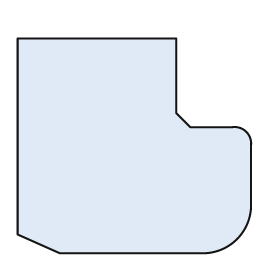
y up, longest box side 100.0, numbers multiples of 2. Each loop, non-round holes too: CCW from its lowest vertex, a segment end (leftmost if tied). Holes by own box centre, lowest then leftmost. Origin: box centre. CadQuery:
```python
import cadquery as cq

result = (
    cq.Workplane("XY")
    .moveTo(-32.0, -46.0)
    .lineTo(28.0, -46.0)
    .threePointArc((44.0, -40.0), (50.0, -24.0))
    .lineTo(50.0, 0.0)
    .threePointArc((48.0, 6.0), (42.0, 8.0))
    .lineTo(24.0, 8.0)
    .lineTo(18.0, 14.0)
    .lineTo(18.0, 46.0)
    .lineTo(-50.0, 46.0)
    .lineTo(-50.0, -38.0)
    .close()
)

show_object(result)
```